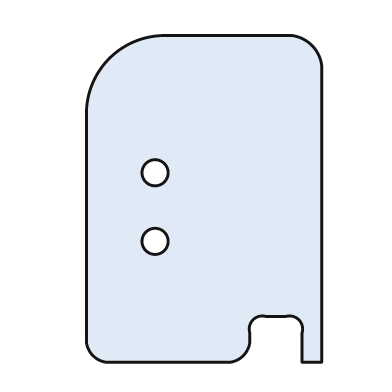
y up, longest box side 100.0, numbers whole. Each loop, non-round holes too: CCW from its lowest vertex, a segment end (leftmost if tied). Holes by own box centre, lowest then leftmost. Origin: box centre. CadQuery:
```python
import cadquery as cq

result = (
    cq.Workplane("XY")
    .moveTo(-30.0, -50.0)
    .lineTo(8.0, -50.0)
    .threePointArc((12.0, -48.0), (14.0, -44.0))
    .lineTo(14.0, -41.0)
    .threePointArc((15.0, -37.0), (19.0, -36.0))
    .lineTo(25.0, -36.0)
    .threePointArc((29.0, -37.0), (30.0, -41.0))
    .lineTo(30.0, -50.0)
    .lineTo(36.0, -50.0)
    .lineTo(36.0, 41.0)
    .threePointArc((33.0, 47.0), (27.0, 50.0))
    .lineTo(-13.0, 50.0)
    .threePointArc((-29.0, 43.0), (-36.0, 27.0))
    .lineTo(-36.0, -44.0)
    .threePointArc((-34.0, -48.0), (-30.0, -50.0))
    .close()
    .moveTo(-15.0, -13.0)
    .circle(4.0)
    .moveTo(-15.0, 8.0)
    .circle(4.0)
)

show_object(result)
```